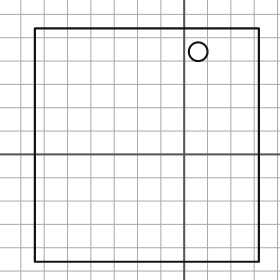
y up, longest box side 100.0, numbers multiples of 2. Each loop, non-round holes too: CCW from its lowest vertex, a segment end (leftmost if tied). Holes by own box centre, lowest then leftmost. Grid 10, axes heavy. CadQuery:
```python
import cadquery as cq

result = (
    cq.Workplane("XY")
    .moveTo(-64.0, -46.0)
    .lineTo(32.0, -46.0)
    .lineTo(32.0, 54.0)
    .lineTo(-64.0, 54.0)
    .close()
    .moveTo(6.0, 44.0)
    .circle(4.0)
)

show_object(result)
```